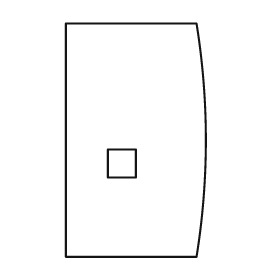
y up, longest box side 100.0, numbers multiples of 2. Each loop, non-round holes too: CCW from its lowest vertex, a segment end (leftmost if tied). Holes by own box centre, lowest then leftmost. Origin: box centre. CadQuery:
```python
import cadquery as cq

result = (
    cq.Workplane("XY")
    .moveTo(-30.0, -50.0)
    .lineTo(26.0, -50.0)
    .threePointArc((30.0, 0.0), (26.0, 50.0))
    .lineTo(-30.0, 50.0)
    .close()
    .moveTo(-12.0, -16.0)
    .lineTo(0.0, -16.0)
    .lineTo(0.0, -4.0)
    .lineTo(-12.0, -4.0)
    .close()
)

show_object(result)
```